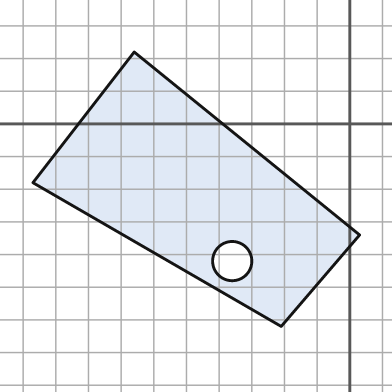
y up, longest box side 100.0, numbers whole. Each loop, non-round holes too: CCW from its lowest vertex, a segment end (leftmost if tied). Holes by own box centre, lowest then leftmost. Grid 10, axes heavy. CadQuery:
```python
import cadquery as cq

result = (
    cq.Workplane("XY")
    .moveTo(-21.0, -62.0)
    .lineTo(3.0, -34.0)
    .lineTo(-66.0, 22.0)
    .lineTo(-97.0, -18.0)
    .close()
    .moveTo(-36.0, -42.0)
    .circle(6.0)
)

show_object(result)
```